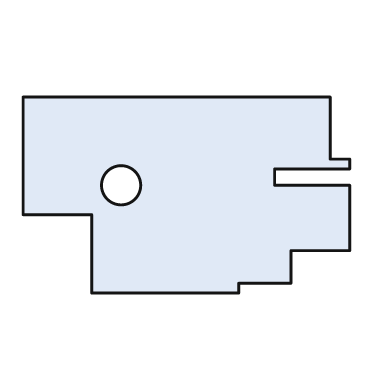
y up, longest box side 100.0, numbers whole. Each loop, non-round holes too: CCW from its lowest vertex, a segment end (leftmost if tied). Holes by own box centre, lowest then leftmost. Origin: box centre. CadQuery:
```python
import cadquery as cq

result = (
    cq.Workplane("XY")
    .moveTo(-29.0, -30.0)
    .lineTo(16.0, -30.0)
    .lineTo(16.0, -27.0)
    .lineTo(32.0, -27.0)
    .lineTo(32.0, -17.0)
    .lineTo(50.0, -17.0)
    .lineTo(50.0, 3.0)
    .lineTo(27.0, 3.0)
    .lineTo(27.0, 8.0)
    .lineTo(50.0, 8.0)
    .lineTo(50.0, 11.0)
    .lineTo(44.0, 11.0)
    .lineTo(44.0, 30.0)
    .lineTo(-50.0, 30.0)
    .lineTo(-50.0, -6.0)
    .lineTo(-29.0, -6.0)
    .close()
    .moveTo(-20.0, 3.0)
    .circle(6.0)
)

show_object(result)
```